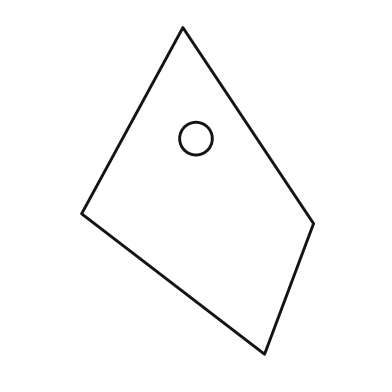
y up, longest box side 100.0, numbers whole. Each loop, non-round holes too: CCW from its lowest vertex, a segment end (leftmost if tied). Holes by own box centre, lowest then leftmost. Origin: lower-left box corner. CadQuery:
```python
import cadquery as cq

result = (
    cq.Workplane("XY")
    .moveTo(56.0, 0.0)
    .lineTo(71.0, 40.0)
    .lineTo(31.0, 100.0)
    .lineTo(0.0, 43.0)
    .close()
    .moveTo(35.0, 66.0)
    .circle(5.0)
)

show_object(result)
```